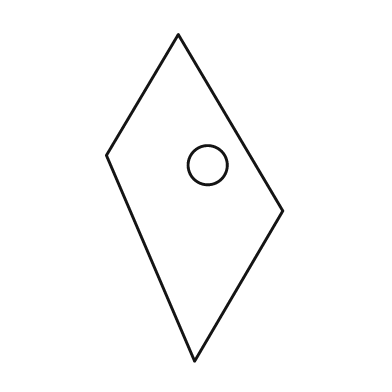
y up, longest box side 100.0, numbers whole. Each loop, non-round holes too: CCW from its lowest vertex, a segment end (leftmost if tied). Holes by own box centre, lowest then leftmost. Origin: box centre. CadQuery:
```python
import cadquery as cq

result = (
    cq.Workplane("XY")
    .moveTo(0.0, -50.0)
    .lineTo(27.0, -4.0)
    .lineTo(-5.0, 50.0)
    .lineTo(-27.0, 13.0)
    .close()
    .moveTo(4.0, 10.0)
    .circle(6.0)
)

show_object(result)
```